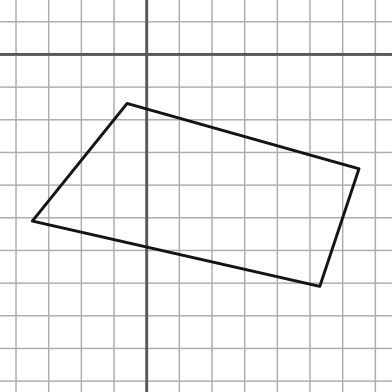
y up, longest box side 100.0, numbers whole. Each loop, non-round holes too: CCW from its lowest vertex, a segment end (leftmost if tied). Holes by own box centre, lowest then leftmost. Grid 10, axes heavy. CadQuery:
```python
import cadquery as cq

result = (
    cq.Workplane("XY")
    .moveTo(53.0, -71.0)
    .lineTo(65.0, -35.0)
    .lineTo(-6.0, -15.0)
    .lineTo(-35.0, -51.0)
    .close()
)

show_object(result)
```